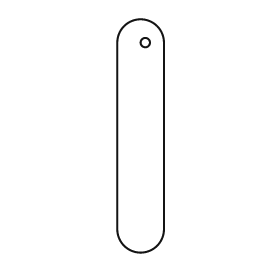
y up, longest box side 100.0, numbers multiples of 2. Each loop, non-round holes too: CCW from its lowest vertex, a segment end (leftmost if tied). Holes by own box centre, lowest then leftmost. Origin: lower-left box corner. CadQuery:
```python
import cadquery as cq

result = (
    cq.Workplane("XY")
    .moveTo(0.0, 10.0)
    .threePointArc((10.0, 0.0), (20.0, 10.0))
    .lineTo(20.0, 90.0)
    .threePointArc((10.0, 100.0), (0.0, 90.0))
    .close()
    .moveTo(12.0, 90.0)
    .circle(2.0)
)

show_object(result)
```